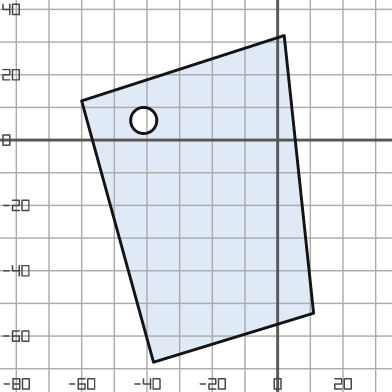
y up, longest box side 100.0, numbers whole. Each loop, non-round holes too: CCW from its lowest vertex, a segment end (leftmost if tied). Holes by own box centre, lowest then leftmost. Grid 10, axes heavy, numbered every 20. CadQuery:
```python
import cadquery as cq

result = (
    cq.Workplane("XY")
    .moveTo(-38.0, -68.0)
    .lineTo(11.0, -53.0)
    .lineTo(2.0, 32.0)
    .lineTo(-60.0, 12.0)
    .close()
    .moveTo(-41.0, 6.0)
    .circle(4.0)
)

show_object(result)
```